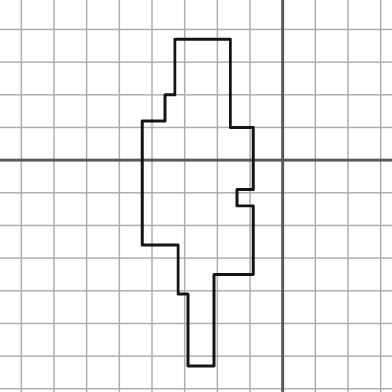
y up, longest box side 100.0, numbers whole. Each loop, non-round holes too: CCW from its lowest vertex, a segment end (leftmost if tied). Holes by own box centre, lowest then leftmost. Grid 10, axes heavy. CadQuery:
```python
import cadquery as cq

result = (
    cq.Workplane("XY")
    .moveTo(-29.0, -63.0)
    .lineTo(-21.0, -63.0)
    .lineTo(-21.0, -35.0)
    .lineTo(-9.0, -35.0)
    .lineTo(-9.0, -14.0)
    .lineTo(-14.0, -14.0)
    .lineTo(-14.0, -9.0)
    .lineTo(-9.0, -9.0)
    .lineTo(-9.0, 10.0)
    .lineTo(-16.0, 10.0)
    .lineTo(-16.0, 37.0)
    .lineTo(-33.0, 37.0)
    .lineTo(-33.0, 20.0)
    .lineTo(-36.0, 20.0)
    .lineTo(-36.0, 12.0)
    .lineTo(-43.0, 12.0)
    .lineTo(-43.0, -26.0)
    .lineTo(-32.0, -26.0)
    .lineTo(-32.0, -41.0)
    .lineTo(-29.0, -41.0)
    .close()
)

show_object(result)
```